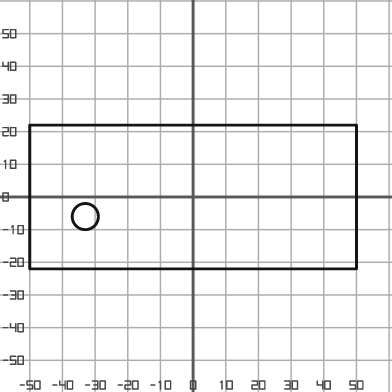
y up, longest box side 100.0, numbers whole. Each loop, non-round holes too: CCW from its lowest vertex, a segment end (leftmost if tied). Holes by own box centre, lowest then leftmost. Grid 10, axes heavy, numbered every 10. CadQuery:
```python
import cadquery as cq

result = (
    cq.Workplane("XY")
    .moveTo(-50.0, -22.0)
    .lineTo(50.0, -22.0)
    .lineTo(50.0, 22.0)
    .lineTo(-50.0, 22.0)
    .close()
    .moveTo(-33.0, -6.0)
    .circle(4.0)
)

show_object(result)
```